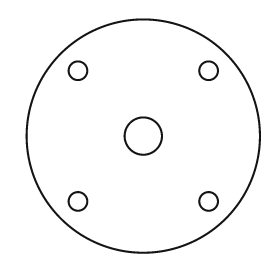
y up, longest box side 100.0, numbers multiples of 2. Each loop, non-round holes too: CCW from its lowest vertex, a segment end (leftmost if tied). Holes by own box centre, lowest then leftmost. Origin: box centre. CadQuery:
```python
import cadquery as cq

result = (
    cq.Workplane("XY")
    .moveTo(0.0, 0.0)
    .circle(50.0)
    .moveTo(-28.0, -28.0)
    .circle(4.0)
    .moveTo(28.0, -28.0)
    .circle(4.0)
    .moveTo(0.0, 0.0)
    .circle(8.0)
    .moveTo(-28.0, 28.0)
    .circle(4.0)
    .moveTo(28.0, 28.0)
    .circle(4.0)
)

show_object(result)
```